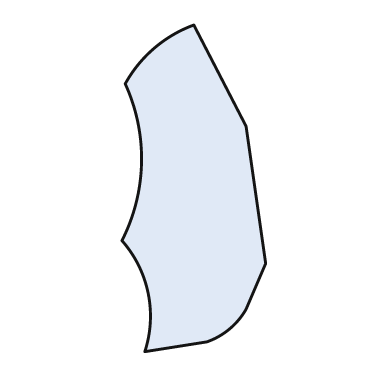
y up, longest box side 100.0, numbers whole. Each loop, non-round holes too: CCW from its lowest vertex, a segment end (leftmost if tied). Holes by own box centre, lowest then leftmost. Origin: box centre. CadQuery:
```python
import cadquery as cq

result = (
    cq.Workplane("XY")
    .moveTo(-15.0, -50.0)
    .lineTo(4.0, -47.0)
    .threePointArc((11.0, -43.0), (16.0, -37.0))
    .lineTo(22.0, -23.0)
    .lineTo(16.0, 19.0)
    .lineTo(0.0, 50.0)
    .threePointArc((-12.0, 43.0), (-21.0, 32.0))
    .threePointArc((-16.0, 8.0), (-22.0, -16.0))
    .threePointArc((-14.0, -32.0), (-15.0, -50.0))
    .close()
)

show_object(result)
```